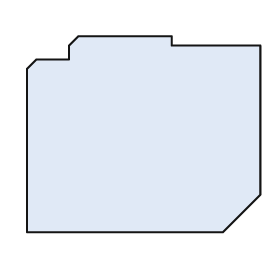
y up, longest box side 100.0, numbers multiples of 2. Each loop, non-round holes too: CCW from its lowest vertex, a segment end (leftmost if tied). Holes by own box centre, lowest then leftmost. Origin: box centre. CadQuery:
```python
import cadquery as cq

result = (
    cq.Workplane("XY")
    .moveTo(-50.0, -42.0)
    .lineTo(34.0, -42.0)
    .lineTo(50.0, -26.0)
    .lineTo(50.0, 38.0)
    .lineTo(12.0, 38.0)
    .lineTo(12.0, 42.0)
    .lineTo(-28.0, 42.0)
    .lineTo(-32.0, 38.0)
    .lineTo(-32.0, 32.0)
    .lineTo(-46.0, 32.0)
    .lineTo(-50.0, 28.0)
    .close()
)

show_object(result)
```